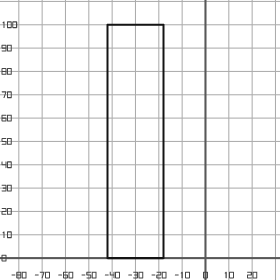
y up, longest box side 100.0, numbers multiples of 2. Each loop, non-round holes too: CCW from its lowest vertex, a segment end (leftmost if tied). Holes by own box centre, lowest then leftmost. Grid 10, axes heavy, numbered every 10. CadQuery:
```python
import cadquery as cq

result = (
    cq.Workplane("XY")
    .moveTo(-42.0, 0.0)
    .lineTo(-18.0, 0.0)
    .lineTo(-18.0, 100.0)
    .lineTo(-42.0, 100.0)
    .close()
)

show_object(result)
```